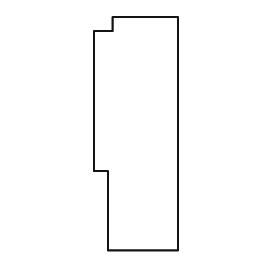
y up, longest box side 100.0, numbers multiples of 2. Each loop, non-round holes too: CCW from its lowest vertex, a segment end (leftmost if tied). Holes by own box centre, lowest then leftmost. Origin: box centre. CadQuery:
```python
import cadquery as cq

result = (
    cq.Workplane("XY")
    .moveTo(-12.0, -50.0)
    .lineTo(18.0, -50.0)
    .lineTo(18.0, 50.0)
    .lineTo(-10.0, 50.0)
    .lineTo(-10.0, 44.0)
    .lineTo(-18.0, 44.0)
    .lineTo(-18.0, -16.0)
    .lineTo(-12.0, -16.0)
    .close()
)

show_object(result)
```